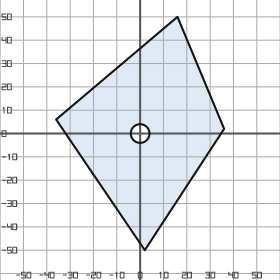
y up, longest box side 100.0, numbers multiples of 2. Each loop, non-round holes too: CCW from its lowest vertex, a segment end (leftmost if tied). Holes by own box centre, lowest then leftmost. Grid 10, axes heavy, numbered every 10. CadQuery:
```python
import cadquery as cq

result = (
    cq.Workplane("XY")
    .moveTo(2.0, -50.0)
    .lineTo(36.0, 2.0)
    .lineTo(16.0, 50.0)
    .lineTo(-36.0, 6.0)
    .close()
    .moveTo(0.0, 0.0)
    .circle(4.0)
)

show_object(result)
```